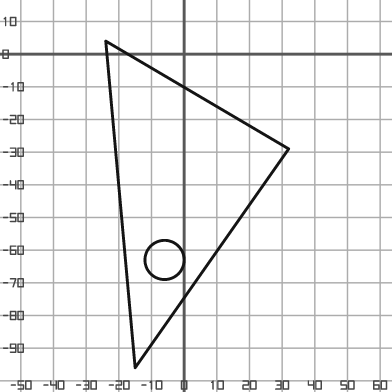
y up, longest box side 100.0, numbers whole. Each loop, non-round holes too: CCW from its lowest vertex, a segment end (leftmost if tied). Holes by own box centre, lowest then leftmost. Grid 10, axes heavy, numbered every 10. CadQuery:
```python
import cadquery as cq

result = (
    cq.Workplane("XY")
    .moveTo(-15.0, -96.0)
    .lineTo(32.0, -29.0)
    .lineTo(-24.0, 4.0)
    .close()
    .moveTo(-6.0, -63.0)
    .circle(6.0)
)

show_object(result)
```